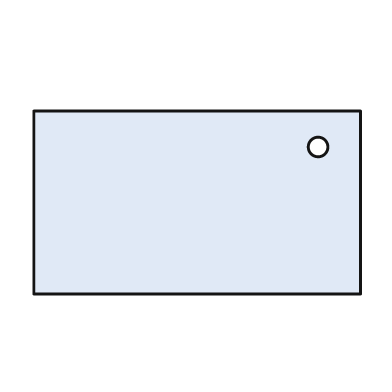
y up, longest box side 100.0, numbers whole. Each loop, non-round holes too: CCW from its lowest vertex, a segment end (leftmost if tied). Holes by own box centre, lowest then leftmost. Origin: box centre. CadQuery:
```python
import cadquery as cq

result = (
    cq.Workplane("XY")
    .moveTo(-50.0, -28.0)
    .lineTo(50.0, -28.0)
    .lineTo(50.0, 28.0)
    .lineTo(-50.0, 28.0)
    .close()
    .moveTo(37.0, 17.0)
    .circle(3.0)
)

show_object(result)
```